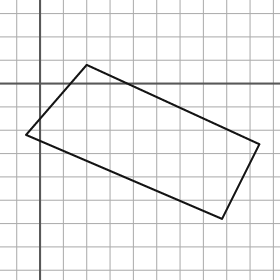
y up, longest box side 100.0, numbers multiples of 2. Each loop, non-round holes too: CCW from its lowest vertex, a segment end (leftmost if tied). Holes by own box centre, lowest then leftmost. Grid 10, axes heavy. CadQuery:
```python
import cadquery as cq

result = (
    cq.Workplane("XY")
    .moveTo(78.0, -58.0)
    .lineTo(94.0, -26.0)
    .lineTo(20.0, 8.0)
    .lineTo(-6.0, -22.0)
    .close()
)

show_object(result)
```